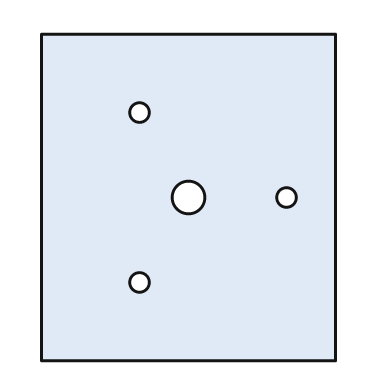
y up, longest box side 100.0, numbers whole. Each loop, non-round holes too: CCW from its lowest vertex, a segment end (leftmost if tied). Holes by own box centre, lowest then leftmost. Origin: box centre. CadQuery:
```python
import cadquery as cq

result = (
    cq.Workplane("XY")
    .moveTo(-45.0, -50.0)
    .lineTo(45.0, -50.0)
    .lineTo(45.0, 50.0)
    .lineTo(-45.0, 50.0)
    .close()
    .moveTo(-15.0, -26.0)
    .circle(3.0)
    .moveTo(0.0, 0.0)
    .circle(5.0)
    .moveTo(30.0, 0.0)
    .circle(3.0)
    .moveTo(-15.0, 26.0)
    .circle(3.0)
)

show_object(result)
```